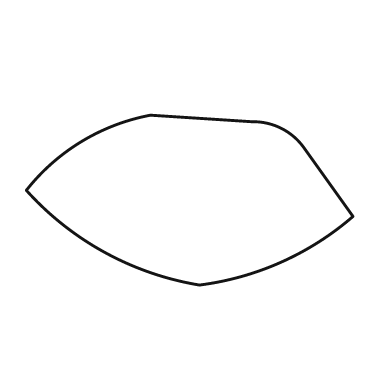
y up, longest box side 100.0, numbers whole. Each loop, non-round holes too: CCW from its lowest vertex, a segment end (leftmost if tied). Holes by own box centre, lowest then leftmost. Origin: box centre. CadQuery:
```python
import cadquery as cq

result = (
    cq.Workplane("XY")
    .moveTo(3.0, -26.0)
    .threePointArc((28.0, -19.0), (50.0, -5.0))
    .lineTo(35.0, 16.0)
    .threePointArc((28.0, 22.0), (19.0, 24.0))
    .lineTo(-12.0, 26.0)
    .threePointArc((-33.0, 18.0), (-50.0, 3.0))
    .threePointArc((-26.0, -16.0), (3.0, -26.0))
    .close()
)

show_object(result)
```